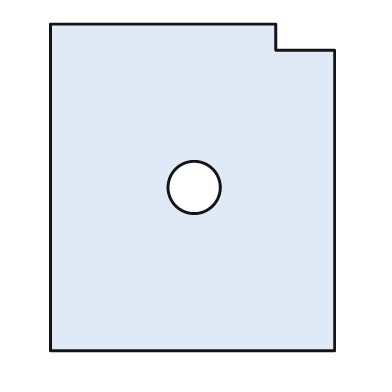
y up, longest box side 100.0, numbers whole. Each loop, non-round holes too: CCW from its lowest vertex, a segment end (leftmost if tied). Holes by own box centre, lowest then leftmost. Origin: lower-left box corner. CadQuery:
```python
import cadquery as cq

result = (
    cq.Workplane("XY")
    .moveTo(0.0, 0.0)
    .lineTo(87.0, 0.0)
    .lineTo(87.0, 92.0)
    .lineTo(69.0, 92.0)
    .lineTo(69.0, 100.0)
    .lineTo(0.0, 100.0)
    .close()
    .moveTo(44.0, 50.0)
    .circle(8.0)
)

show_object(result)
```